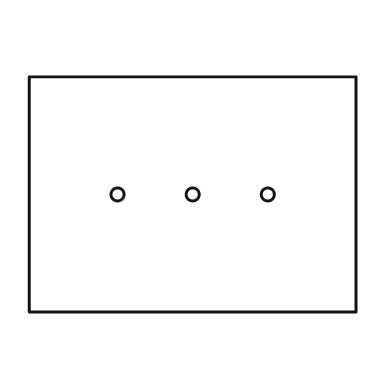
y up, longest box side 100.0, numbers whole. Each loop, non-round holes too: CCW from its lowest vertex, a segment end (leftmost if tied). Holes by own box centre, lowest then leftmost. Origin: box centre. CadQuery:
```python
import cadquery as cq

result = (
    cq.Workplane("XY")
    .moveTo(-50.0, -36.0)
    .lineTo(50.0, -36.0)
    .lineTo(50.0, 36.0)
    .lineTo(-50.0, 36.0)
    .close()
    .moveTo(-23.0, 0.0)
    .circle(2.0)
    .moveTo(0.0, 0.0)
    .circle(2.0)
    .moveTo(23.0, 0.0)
    .circle(2.0)
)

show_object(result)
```